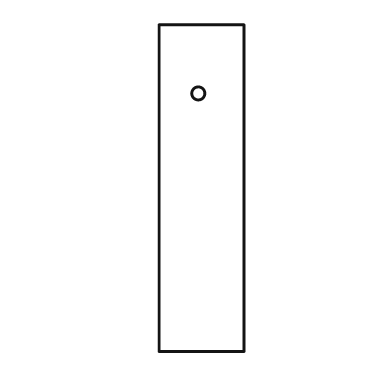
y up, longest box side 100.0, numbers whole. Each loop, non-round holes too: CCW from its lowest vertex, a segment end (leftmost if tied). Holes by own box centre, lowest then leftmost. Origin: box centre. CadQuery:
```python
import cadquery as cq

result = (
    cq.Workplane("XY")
    .moveTo(-13.0, -50.0)
    .lineTo(13.0, -50.0)
    .lineTo(13.0, 50.0)
    .lineTo(-13.0, 50.0)
    .close()
    .moveTo(-1.0, 29.0)
    .circle(2.0)
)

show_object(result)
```